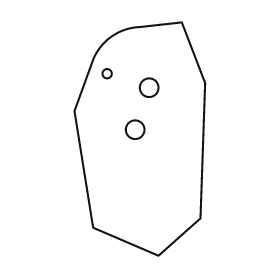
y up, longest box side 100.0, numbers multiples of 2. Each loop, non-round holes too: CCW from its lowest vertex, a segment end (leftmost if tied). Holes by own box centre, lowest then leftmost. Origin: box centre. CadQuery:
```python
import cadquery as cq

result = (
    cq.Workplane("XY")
    .moveTo(8.0, -50.0)
    .lineTo(26.0, -34.0)
    .lineTo(28.0, 24.0)
    .lineTo(18.0, 50.0)
    .lineTo(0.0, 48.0)
    .threePointArc((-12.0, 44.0), (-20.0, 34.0))
    .lineTo(-28.0, 12.0)
    .lineTo(-20.0, -38.0)
    .close()
    .moveTo(-2.0, 4.0)
    .circle(4.0)
    .moveTo(4.0, 22.0)
    .circle(4.0)
    .moveTo(-14.0, 28.0)
    .circle(2.0)
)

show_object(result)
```